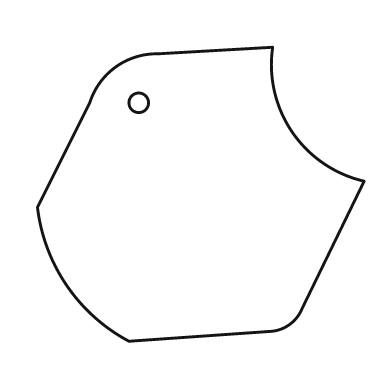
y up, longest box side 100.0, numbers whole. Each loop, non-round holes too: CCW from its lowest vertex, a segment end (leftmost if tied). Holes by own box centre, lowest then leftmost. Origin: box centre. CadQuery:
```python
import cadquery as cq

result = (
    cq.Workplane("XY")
    .moveTo(-22.0, -45.0)
    .lineTo(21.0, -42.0)
    .threePointArc((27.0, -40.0), (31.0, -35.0))
    .lineTo(50.0, 4.0)
    .threePointArc((28.0, 19.0), (22.0, 45.0))
    .lineTo(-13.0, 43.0)
    .threePointArc((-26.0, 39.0), (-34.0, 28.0))
    .lineTo(-50.0, -4.0)
    .threePointArc((-41.0, -28.0), (-22.0, -45.0))
    .close()
    .moveTo(-19.0, 28.0)
    .circle(3.0)
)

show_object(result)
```